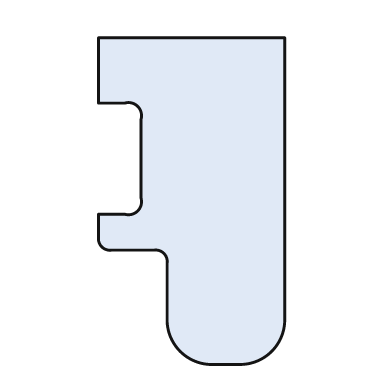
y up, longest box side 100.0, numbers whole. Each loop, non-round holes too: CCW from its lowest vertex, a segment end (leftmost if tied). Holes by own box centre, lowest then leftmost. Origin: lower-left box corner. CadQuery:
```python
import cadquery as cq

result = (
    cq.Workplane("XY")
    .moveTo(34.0, 0.0)
    .lineTo(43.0, 0.0)
    .threePointArc((53.0, 4.0), (57.0, 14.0))
    .lineTo(57.0, 100.0)
    .lineTo(0.0, 100.0)
    .lineTo(0.0, 80.0)
    .lineTo(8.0, 80.0)
    .threePointArc((12.0, 79.0), (13.0, 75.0))
    .lineTo(13.0, 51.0)
    .threePointArc((12.0, 47.0), (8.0, 46.0))
    .lineTo(0.0, 46.0)
    .lineTo(0.0, 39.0)
    .threePointArc((1.0, 36.0), (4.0, 35.0))
    .lineTo(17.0, 35.0)
    .threePointArc((20.0, 34.0), (21.0, 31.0))
    .lineTo(21.0, 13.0)
    .threePointArc((25.0, 4.0), (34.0, 0.0))
    .close()
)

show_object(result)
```